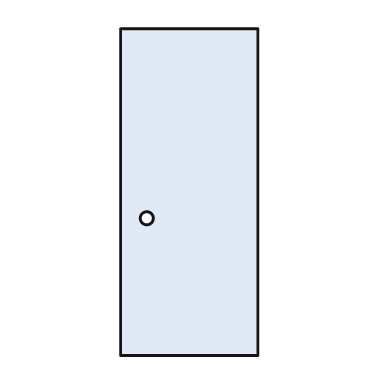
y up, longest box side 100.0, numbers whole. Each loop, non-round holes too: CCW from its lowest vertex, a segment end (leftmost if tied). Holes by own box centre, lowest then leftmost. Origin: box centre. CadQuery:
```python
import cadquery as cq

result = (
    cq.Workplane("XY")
    .moveTo(-21.0, -50.0)
    .lineTo(21.0, -50.0)
    .lineTo(21.0, 50.0)
    .lineTo(-21.0, 50.0)
    .close()
    .moveTo(-13.0, -8.0)
    .circle(2.0)
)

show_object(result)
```